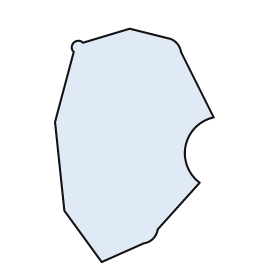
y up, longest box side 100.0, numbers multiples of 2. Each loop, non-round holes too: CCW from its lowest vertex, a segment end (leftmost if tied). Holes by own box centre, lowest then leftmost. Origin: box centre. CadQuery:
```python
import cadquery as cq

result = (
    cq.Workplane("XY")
    .moveTo(-14.0, -50.0)
    .lineTo(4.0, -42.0)
    .threePointArc((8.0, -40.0), (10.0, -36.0))
    .lineTo(28.0, -16.0)
    .threePointArc((22.0, 0.0), (34.0, 12.0))
    .lineTo(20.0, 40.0)
    .threePointArc((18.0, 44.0), (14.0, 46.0))
    .lineTo(-2.0, 50.0)
    .lineTo(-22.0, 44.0)
    .threePointArc((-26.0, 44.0), (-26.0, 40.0))
    .lineTo(-34.0, 10.0)
    .lineTo(-30.0, -28.0)
    .close()
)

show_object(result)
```